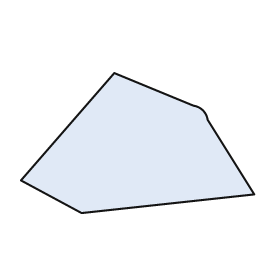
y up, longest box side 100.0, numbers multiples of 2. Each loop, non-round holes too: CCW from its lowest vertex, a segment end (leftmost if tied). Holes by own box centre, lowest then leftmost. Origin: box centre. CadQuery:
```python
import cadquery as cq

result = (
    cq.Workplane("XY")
    .moveTo(-24.0, -30.0)
    .lineTo(50.0, -22.0)
    .lineTo(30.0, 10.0)
    .threePointArc((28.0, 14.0), (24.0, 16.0))
    .lineTo(-10.0, 30.0)
    .lineTo(-50.0, -16.0)
    .close()
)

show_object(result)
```